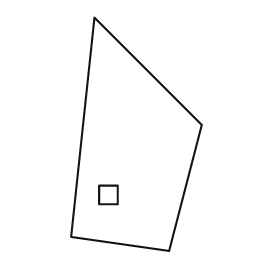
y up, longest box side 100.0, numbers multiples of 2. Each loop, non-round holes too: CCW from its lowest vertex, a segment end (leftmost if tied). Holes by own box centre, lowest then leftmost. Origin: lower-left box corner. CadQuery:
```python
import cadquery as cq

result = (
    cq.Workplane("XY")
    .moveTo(42.0, 0.0)
    .lineTo(56.0, 54.0)
    .lineTo(10.0, 100.0)
    .lineTo(0.0, 6.0)
    .close()
    .moveTo(12.0, 20.0)
    .lineTo(20.0, 20.0)
    .lineTo(20.0, 28.0)
    .lineTo(12.0, 28.0)
    .close()
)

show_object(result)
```